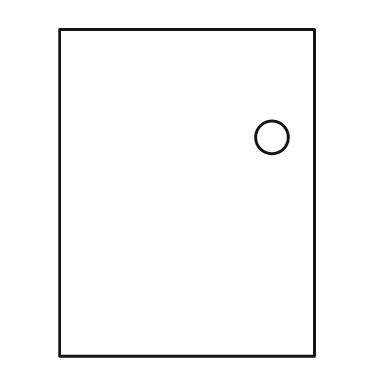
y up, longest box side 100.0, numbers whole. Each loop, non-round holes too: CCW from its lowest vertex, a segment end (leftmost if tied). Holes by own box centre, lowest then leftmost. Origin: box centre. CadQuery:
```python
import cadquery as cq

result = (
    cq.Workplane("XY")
    .moveTo(-39.0, -50.0)
    .lineTo(39.0, -50.0)
    .lineTo(39.0, 50.0)
    .lineTo(-39.0, 50.0)
    .close()
    .moveTo(26.0, 17.0)
    .circle(5.0)
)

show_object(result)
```